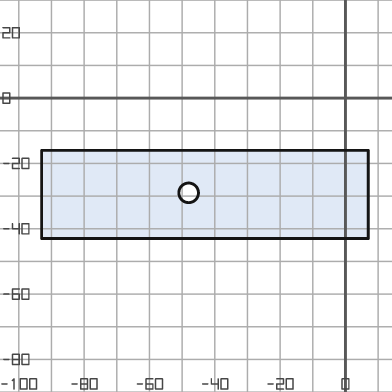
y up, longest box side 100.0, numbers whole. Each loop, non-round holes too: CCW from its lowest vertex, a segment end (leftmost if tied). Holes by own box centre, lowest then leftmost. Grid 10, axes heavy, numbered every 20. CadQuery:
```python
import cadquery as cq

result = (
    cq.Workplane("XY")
    .moveTo(-93.0, -43.0)
    .lineTo(7.0, -43.0)
    .lineTo(7.0, -16.0)
    .lineTo(-93.0, -16.0)
    .close()
    .moveTo(-48.0, -29.0)
    .circle(3.0)
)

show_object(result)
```